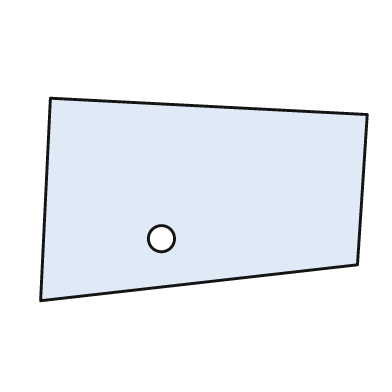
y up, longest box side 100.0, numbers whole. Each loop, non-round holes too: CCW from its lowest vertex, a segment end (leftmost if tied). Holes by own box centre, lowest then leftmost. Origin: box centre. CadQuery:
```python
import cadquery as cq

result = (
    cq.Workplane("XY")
    .moveTo(-50.0, -31.0)
    .lineTo(47.0, -20.0)
    .lineTo(50.0, 26.0)
    .lineTo(-47.0, 31.0)
    .close()
    .moveTo(-13.0, -12.0)
    .circle(4.0)
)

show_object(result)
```